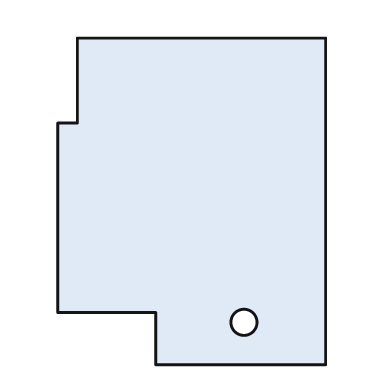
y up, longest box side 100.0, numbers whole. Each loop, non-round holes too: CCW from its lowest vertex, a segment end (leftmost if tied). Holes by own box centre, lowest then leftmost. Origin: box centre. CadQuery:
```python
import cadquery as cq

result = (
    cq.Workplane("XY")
    .moveTo(-11.0, -50.0)
    .lineTo(41.0, -50.0)
    .lineTo(41.0, 50.0)
    .lineTo(-35.0, 50.0)
    .lineTo(-35.0, 24.0)
    .lineTo(-41.0, 24.0)
    .lineTo(-41.0, -34.0)
    .lineTo(-11.0, -34.0)
    .close()
    .moveTo(16.0, -37.0)
    .circle(4.0)
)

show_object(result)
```